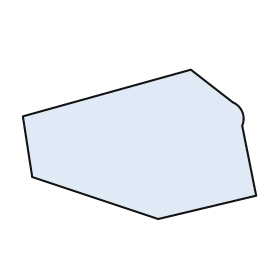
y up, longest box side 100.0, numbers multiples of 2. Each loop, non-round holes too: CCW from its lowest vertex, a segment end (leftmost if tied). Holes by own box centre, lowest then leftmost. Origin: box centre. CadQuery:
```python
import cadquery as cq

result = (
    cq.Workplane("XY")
    .moveTo(8.0, -32.0)
    .lineTo(50.0, -22.0)
    .lineTo(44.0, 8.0)
    .threePointArc((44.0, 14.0), (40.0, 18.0))
    .lineTo(22.0, 32.0)
    .lineTo(-50.0, 12.0)
    .lineTo(-46.0, -14.0)
    .close()
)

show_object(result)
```